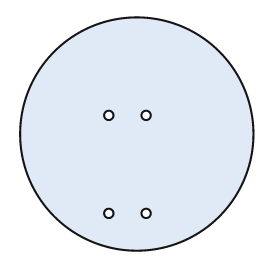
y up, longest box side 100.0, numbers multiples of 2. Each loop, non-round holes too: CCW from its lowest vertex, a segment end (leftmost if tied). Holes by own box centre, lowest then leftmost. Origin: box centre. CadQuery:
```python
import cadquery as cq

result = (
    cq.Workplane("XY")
    .moveTo(0.0, 0.0)
    .circle(50.0)
    .moveTo(-12.0, -34.0)
    .circle(2.0)
    .moveTo(4.0, -34.0)
    .circle(2.0)
    .moveTo(-12.0, 8.0)
    .circle(2.0)
    .moveTo(4.0, 8.0)
    .circle(2.0)
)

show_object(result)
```